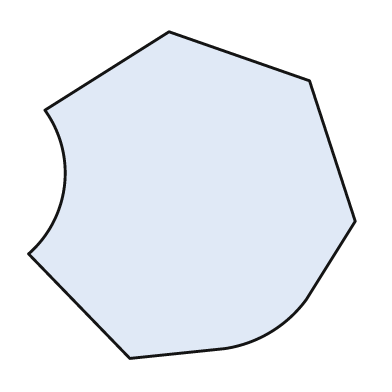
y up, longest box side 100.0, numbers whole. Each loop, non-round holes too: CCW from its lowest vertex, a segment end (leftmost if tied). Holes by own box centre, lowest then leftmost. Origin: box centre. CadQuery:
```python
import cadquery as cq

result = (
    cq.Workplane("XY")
    .moveTo(-19.0, -50.0)
    .lineTo(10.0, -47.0)
    .threePointArc((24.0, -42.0), (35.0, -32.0))
    .lineTo(50.0, -8.0)
    .lineTo(36.0, 35.0)
    .lineTo(-7.0, 50.0)
    .lineTo(-45.0, 26.0)
    .threePointArc((-39.0, 3.0), (-50.0, -18.0))
    .close()
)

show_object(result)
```